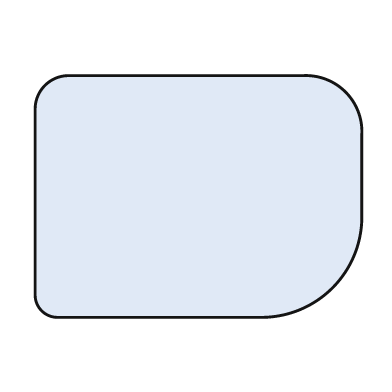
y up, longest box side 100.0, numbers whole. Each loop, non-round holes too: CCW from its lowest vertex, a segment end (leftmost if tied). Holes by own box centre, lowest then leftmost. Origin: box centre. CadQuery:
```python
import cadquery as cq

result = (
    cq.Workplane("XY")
    .moveTo(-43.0, -37.0)
    .lineTo(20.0, -37.0)
    .threePointArc((41.0, -28.0), (50.0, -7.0))
    .lineTo(50.0, 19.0)
    .threePointArc((45.0, 32.0), (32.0, 37.0))
    .lineTo(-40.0, 37.0)
    .threePointArc((-47.0, 34.0), (-50.0, 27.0))
    .lineTo(-50.0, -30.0)
    .threePointArc((-48.0, -35.0), (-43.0, -37.0))
    .close()
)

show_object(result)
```